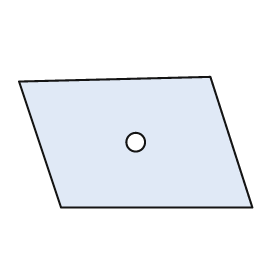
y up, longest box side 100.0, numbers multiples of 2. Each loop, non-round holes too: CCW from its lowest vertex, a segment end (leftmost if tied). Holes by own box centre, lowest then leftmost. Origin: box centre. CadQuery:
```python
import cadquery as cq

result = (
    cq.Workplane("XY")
    .moveTo(-32.0, -28.0)
    .lineTo(50.0, -28.0)
    .lineTo(32.0, 28.0)
    .lineTo(-50.0, 26.0)
    .close()
    .moveTo(0.0, 0.0)
    .circle(4.0)
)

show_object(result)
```